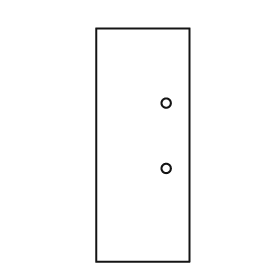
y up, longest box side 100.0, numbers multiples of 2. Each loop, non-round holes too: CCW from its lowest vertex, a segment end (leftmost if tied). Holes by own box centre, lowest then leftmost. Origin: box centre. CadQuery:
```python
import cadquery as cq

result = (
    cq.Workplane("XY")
    .moveTo(-20.0, -50.0)
    .lineTo(20.0, -50.0)
    .lineTo(20.0, 50.0)
    .lineTo(-20.0, 50.0)
    .close()
    .moveTo(10.0, -10.0)
    .circle(2.0)
    .moveTo(10.0, 18.0)
    .circle(2.0)
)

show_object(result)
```